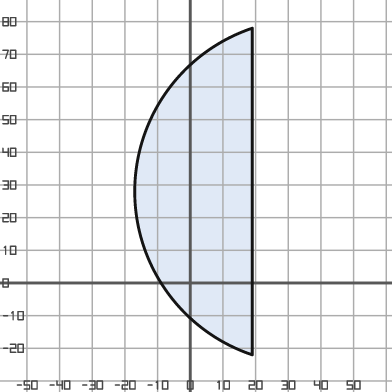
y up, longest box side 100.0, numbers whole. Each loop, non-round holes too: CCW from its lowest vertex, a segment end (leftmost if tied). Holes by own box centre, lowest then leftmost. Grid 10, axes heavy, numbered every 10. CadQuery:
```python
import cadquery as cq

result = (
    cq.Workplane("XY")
    .moveTo(19.0, -22.0)
    .lineTo(19.0, 78.0)
    .threePointArc((-17.0, 28.0), (19.0, -22.0))
    .close()
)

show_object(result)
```